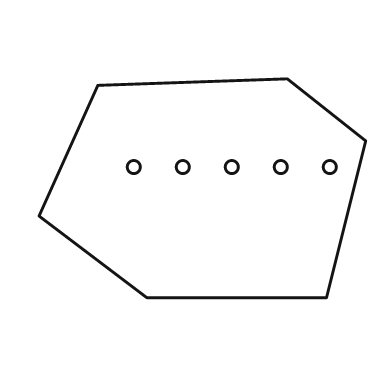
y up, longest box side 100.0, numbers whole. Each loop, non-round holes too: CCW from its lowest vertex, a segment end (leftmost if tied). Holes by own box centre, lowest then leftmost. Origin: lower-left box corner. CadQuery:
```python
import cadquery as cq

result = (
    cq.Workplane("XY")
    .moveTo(33.0, 0.0)
    .lineTo(88.0, 0.0)
    .lineTo(100.0, 48.0)
    .lineTo(76.0, 67.0)
    .lineTo(18.0, 65.0)
    .lineTo(0.0, 25.0)
    .close()
    .moveTo(29.0, 40.0)
    .circle(2.0)
    .moveTo(44.0, 40.0)
    .circle(2.0)
    .moveTo(59.0, 40.0)
    .circle(2.0)
    .moveTo(74.0, 40.0)
    .circle(2.0)
    .moveTo(89.0, 40.0)
    .circle(2.0)
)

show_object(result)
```